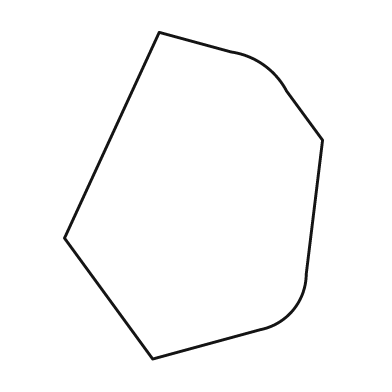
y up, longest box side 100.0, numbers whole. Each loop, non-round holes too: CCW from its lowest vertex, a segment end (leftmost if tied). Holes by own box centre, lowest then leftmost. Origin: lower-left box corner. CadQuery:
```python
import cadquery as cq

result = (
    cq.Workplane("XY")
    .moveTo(27.0, 0.0)
    .lineTo(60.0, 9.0)
    .threePointArc((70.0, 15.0), (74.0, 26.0))
    .lineTo(79.0, 67.0)
    .lineTo(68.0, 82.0)
    .threePointArc((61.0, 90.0), (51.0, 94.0))
    .lineTo(29.0, 100.0)
    .lineTo(0.0, 37.0)
    .close()
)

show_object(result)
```